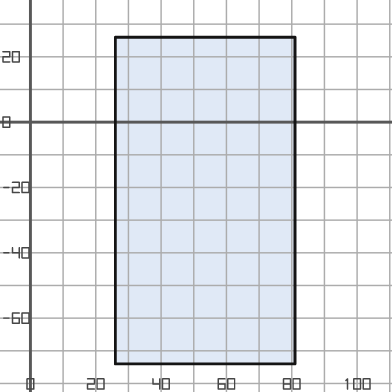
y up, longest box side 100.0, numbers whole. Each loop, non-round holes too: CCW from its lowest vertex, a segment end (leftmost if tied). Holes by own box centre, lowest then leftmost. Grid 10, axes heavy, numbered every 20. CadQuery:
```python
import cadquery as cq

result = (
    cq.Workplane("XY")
    .moveTo(26.0, -74.0)
    .lineTo(81.0, -74.0)
    .lineTo(81.0, 26.0)
    .lineTo(26.0, 26.0)
    .close()
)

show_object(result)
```